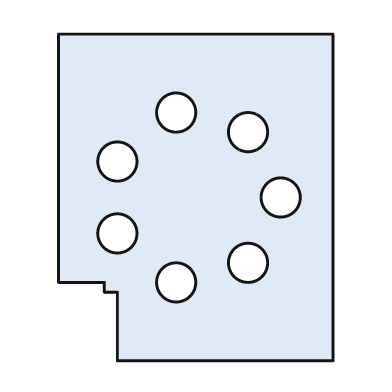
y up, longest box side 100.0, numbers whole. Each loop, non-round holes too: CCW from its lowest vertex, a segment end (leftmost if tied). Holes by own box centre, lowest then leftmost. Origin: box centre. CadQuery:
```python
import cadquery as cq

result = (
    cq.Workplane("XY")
    .moveTo(-24.0, -50.0)
    .lineTo(42.0, -50.0)
    .lineTo(42.0, 50.0)
    .lineTo(-42.0, 50.0)
    .lineTo(-42.0, -26.0)
    .lineTo(-28.0, -26.0)
    .lineTo(-28.0, -29.0)
    .lineTo(-24.0, -29.0)
    .close()
    .moveTo(-6.0, -26.0)
    .circle(6.0)
    .moveTo(16.0, -20.0)
    .circle(6.0)
    .moveTo(-24.0, -11.0)
    .circle(6.0)
    .moveTo(26.0, 0.0)
    .circle(6.0)
    .moveTo(-24.0, 11.0)
    .circle(6.0)
    .moveTo(16.0, 20.0)
    .circle(6.0)
    .moveTo(-6.0, 26.0)
    .circle(6.0)
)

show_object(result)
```